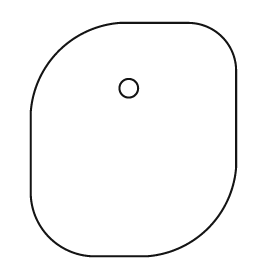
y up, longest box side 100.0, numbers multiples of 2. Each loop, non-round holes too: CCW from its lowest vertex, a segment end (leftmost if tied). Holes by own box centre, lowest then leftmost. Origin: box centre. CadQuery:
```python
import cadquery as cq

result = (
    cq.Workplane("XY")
    .moveTo(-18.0, -50.0)
    .lineTo(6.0, -50.0)
    .threePointArc((32.0, -38.0), (44.0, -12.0))
    .lineTo(44.0, 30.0)
    .threePointArc((38.0, 44.0), (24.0, 50.0))
    .lineTo(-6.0, 50.0)
    .threePointArc((-32.0, 38.0), (-44.0, 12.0))
    .lineTo(-44.0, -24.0)
    .threePointArc((-36.0, -42.0), (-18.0, -50.0))
    .close()
    .moveTo(-2.0, 22.0)
    .circle(4.0)
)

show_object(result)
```